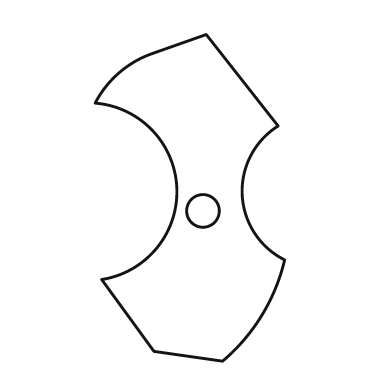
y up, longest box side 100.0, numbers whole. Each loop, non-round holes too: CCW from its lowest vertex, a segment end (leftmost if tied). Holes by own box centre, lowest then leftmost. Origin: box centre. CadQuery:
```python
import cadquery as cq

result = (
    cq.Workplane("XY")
    .moveTo(10.0, -50.0)
    .threePointArc((22.0, -36.0), (29.0, -19.0))
    .threePointArc((16.0, 1.0), (27.0, 22.0))
    .lineTo(5.0, 50.0)
    .lineTo(-12.0, 44.0)
    .threePointArc((-22.0, 38.0), (-29.0, 29.0))
    .threePointArc((-4.0, 3.0), (-27.0, -25.0))
    .lineTo(-11.0, -47.0)
    .close()
    .moveTo(4.0, -4.0)
    .circle(5.0)
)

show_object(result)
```